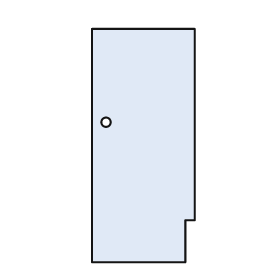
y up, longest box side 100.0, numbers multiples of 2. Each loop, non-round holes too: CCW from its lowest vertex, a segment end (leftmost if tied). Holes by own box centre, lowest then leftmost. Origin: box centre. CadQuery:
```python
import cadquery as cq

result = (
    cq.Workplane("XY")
    .moveTo(-22.0, -50.0)
    .lineTo(18.0, -50.0)
    .lineTo(18.0, -32.0)
    .lineTo(22.0, -32.0)
    .lineTo(22.0, 50.0)
    .lineTo(-22.0, 50.0)
    .close()
    .moveTo(-16.0, 10.0)
    .circle(2.0)
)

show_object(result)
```